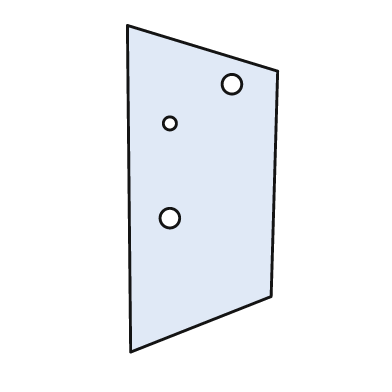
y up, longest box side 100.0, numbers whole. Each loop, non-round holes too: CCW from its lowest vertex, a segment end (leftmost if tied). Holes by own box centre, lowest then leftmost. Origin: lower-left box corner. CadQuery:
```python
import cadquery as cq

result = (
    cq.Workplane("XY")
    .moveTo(1.0, 0.0)
    .lineTo(44.0, 17.0)
    .lineTo(46.0, 86.0)
    .lineTo(0.0, 100.0)
    .close()
    .moveTo(13.0, 41.0)
    .circle(3.0)
    .moveTo(13.0, 70.0)
    .circle(2.0)
    .moveTo(32.0, 82.0)
    .circle(3.0)
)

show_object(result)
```